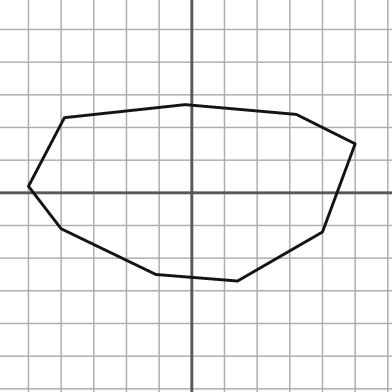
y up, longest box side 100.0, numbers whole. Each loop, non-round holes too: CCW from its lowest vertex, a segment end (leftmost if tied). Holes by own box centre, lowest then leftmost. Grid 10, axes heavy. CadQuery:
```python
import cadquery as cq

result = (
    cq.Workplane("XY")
    .moveTo(14.0, -27.0)
    .lineTo(40.0, -12.0)
    .lineTo(50.0, 15.0)
    .lineTo(32.0, 24.0)
    .lineTo(-2.0, 27.0)
    .lineTo(-39.0, 23.0)
    .lineTo(-50.0, 2.0)
    .lineTo(-40.0, -11.0)
    .lineTo(-11.0, -25.0)
    .close()
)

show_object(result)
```